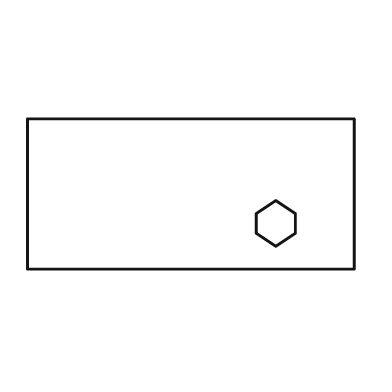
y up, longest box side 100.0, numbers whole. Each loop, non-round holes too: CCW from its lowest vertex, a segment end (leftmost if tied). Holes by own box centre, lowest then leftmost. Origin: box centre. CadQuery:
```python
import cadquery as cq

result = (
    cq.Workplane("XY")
    .moveTo(-50.0, -23.0)
    .lineTo(50.0, -23.0)
    .lineTo(50.0, 23.0)
    .lineTo(-50.0, 23.0)
    .close()
    .moveTo(26.0, -16.0)
    .lineTo(32.0, -12.0)
    .lineTo(32.0, -6.0)
    .lineTo(26.0, -2.0)
    .lineTo(20.0, -6.0)
    .lineTo(20.0, -12.0)
    .close()
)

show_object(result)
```